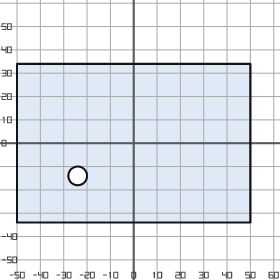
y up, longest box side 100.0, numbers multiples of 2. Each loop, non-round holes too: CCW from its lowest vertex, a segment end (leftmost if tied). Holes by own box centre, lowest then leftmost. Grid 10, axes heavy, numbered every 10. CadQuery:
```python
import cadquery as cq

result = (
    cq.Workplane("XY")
    .moveTo(-50.0, -34.0)
    .lineTo(50.0, -34.0)
    .lineTo(50.0, 34.0)
    .lineTo(-50.0, 34.0)
    .close()
    .moveTo(-24.0, -14.0)
    .circle(4.0)
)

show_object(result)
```